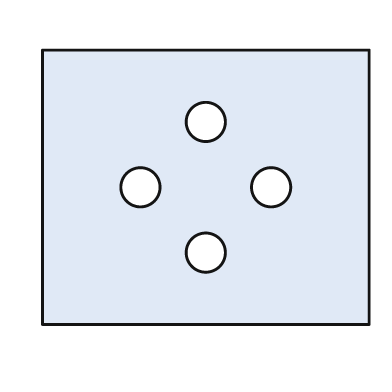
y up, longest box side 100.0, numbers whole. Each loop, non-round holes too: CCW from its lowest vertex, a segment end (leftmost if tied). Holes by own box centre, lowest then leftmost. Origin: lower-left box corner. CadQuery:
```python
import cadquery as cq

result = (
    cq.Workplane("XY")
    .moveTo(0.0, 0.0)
    .lineTo(100.0, 0.0)
    .lineTo(100.0, 84.0)
    .lineTo(0.0, 84.0)
    .close()
    .moveTo(50.0, 22.0)
    .circle(6.0)
    .moveTo(30.0, 42.0)
    .circle(6.0)
    .moveTo(70.0, 42.0)
    .circle(6.0)
    .moveTo(50.0, 62.0)
    .circle(6.0)
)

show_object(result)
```